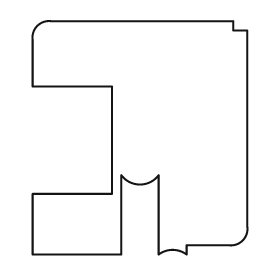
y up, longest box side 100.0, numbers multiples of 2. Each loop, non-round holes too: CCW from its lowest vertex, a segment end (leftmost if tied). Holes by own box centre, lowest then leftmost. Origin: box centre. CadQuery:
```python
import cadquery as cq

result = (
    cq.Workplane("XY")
    .moveTo(-46.0, -50.0)
    .lineTo(-8.0, -50.0)
    .lineTo(-8.0, -16.0)
    .threePointArc((0.0, -20.0), (8.0, -16.0))
    .lineTo(8.0, -50.0)
    .threePointArc((14.0, -48.0), (20.0, -50.0))
    .lineTo(20.0, -46.0)
    .lineTo(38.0, -46.0)
    .threePointArc((44.0, -44.0), (46.0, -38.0))
    .lineTo(46.0, 46.0)
    .lineTo(40.0, 46.0)
    .lineTo(40.0, 50.0)
    .lineTo(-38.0, 50.0)
    .threePointArc((-44.0, 48.0), (-46.0, 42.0))
    .lineTo(-46.0, 22.0)
    .lineTo(-12.0, 22.0)
    .lineTo(-12.0, -24.0)
    .lineTo(-46.0, -24.0)
    .close()
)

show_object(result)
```